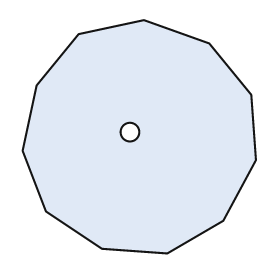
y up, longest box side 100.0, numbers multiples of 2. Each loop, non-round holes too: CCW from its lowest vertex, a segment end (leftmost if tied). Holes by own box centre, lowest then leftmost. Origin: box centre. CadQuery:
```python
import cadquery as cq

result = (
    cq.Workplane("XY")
    .moveTo(12.0, -50.0)
    .lineTo(36.0, -36.0)
    .lineTo(50.0, -10.0)
    .lineTo(48.0, 18.0)
    .lineTo(30.0, 40.0)
    .lineTo(2.0, 50.0)
    .lineTo(-26.0, 44.0)
    .lineTo(-44.0, 22.0)
    .lineTo(-50.0, -6.0)
    .lineTo(-40.0, -32.0)
    .lineTo(-16.0, -48.0)
    .close()
    .moveTo(-4.0, 2.0)
    .circle(4.0)
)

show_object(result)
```